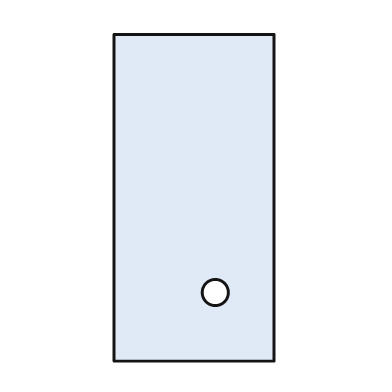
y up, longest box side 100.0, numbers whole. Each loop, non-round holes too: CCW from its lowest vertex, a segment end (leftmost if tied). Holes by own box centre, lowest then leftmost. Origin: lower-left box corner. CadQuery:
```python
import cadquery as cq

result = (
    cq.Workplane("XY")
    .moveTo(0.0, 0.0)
    .lineTo(49.0, 0.0)
    .lineTo(49.0, 100.0)
    .lineTo(0.0, 100.0)
    .close()
    .moveTo(31.0, 21.0)
    .circle(4.0)
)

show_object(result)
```